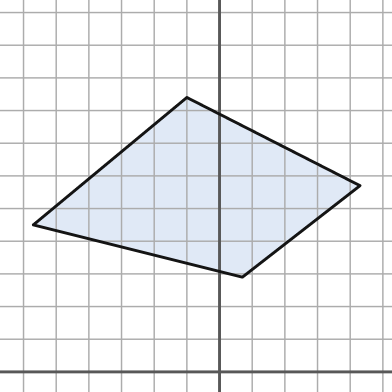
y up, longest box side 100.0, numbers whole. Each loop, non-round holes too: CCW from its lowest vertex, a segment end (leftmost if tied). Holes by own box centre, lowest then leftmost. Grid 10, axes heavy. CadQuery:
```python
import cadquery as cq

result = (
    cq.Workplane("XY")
    .moveTo(7.0, 29.0)
    .lineTo(43.0, 57.0)
    .lineTo(-10.0, 84.0)
    .lineTo(-57.0, 45.0)
    .close()
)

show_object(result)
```